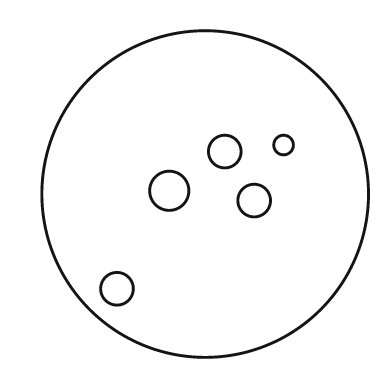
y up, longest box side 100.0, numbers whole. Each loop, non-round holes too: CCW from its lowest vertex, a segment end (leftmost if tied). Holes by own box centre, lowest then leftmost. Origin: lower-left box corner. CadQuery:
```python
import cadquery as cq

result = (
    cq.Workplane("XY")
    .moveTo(50.0, 50.0)
    .circle(50.0)
    .moveTo(23.0, 21.0)
    .circle(5.0)
    .moveTo(65.0, 48.0)
    .circle(5.0)
    .moveTo(39.0, 51.0)
    .circle(6.0)
    .moveTo(56.0, 63.0)
    .circle(5.0)
    .moveTo(74.0, 65.0)
    .circle(3.0)
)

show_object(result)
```